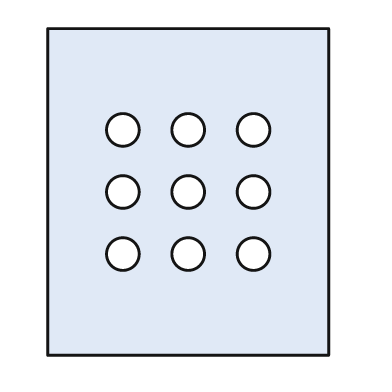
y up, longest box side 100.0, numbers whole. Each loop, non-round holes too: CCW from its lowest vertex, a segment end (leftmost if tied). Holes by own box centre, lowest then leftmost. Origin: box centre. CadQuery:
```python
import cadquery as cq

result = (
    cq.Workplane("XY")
    .moveTo(-43.0, -50.0)
    .lineTo(43.0, -50.0)
    .lineTo(43.0, 50.0)
    .lineTo(-43.0, 50.0)
    .close()
    .moveTo(-20.0, -19.0)
    .circle(5.0)
    .moveTo(0.0, -19.0)
    .circle(5.0)
    .moveTo(20.0, -19.0)
    .circle(5.0)
    .moveTo(-20.0, 0.0)
    .circle(5.0)
    .moveTo(0.0, 0.0)
    .circle(5.0)
    .moveTo(20.0, 0.0)
    .circle(5.0)
    .moveTo(-20.0, 19.0)
    .circle(5.0)
    .moveTo(0.0, 19.0)
    .circle(5.0)
    .moveTo(20.0, 19.0)
    .circle(5.0)
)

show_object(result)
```